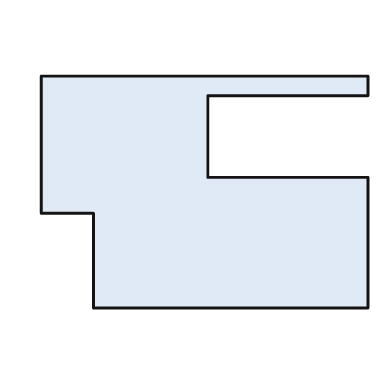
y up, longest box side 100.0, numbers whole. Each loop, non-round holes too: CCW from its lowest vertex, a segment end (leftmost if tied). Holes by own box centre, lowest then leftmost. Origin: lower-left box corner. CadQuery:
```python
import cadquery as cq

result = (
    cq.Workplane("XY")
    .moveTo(16.0, 0.0)
    .lineTo(100.0, 0.0)
    .lineTo(100.0, 40.0)
    .lineTo(51.0, 40.0)
    .lineTo(51.0, 65.0)
    .lineTo(100.0, 65.0)
    .lineTo(100.0, 71.0)
    .lineTo(0.0, 71.0)
    .lineTo(0.0, 29.0)
    .lineTo(16.0, 29.0)
    .close()
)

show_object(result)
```